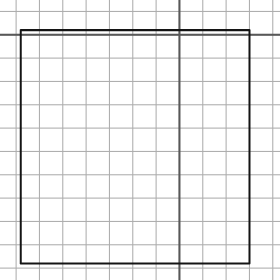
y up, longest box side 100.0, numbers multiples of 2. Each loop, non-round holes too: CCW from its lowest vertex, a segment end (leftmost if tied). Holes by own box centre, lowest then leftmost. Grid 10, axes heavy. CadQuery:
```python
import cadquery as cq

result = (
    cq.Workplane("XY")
    .moveTo(-68.0, -98.0)
    .lineTo(30.0, -98.0)
    .lineTo(30.0, 2.0)
    .lineTo(-68.0, 2.0)
    .close()
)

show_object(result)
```